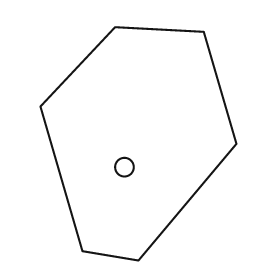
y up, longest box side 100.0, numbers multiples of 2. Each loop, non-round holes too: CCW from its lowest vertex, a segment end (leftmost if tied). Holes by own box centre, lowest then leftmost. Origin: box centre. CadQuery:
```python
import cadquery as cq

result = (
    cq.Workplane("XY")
    .moveTo(0.0, -50.0)
    .lineTo(42.0, 0.0)
    .lineTo(28.0, 48.0)
    .lineTo(-10.0, 50.0)
    .lineTo(-42.0, 16.0)
    .lineTo(-24.0, -46.0)
    .close()
    .moveTo(-6.0, -10.0)
    .circle(4.0)
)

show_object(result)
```